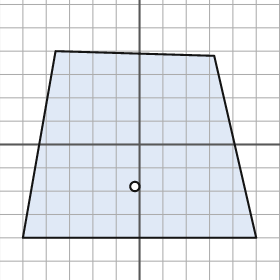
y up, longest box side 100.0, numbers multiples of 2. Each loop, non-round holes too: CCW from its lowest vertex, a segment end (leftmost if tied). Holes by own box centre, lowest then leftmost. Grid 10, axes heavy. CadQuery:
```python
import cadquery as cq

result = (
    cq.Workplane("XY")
    .moveTo(-50.0, -40.0)
    .lineTo(50.0, -40.0)
    .lineTo(32.0, 38.0)
    .lineTo(-36.0, 40.0)
    .close()
    .moveTo(-2.0, -18.0)
    .circle(2.0)
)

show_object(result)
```